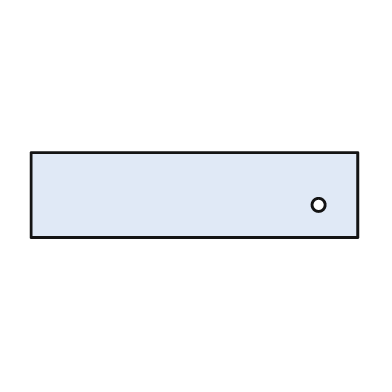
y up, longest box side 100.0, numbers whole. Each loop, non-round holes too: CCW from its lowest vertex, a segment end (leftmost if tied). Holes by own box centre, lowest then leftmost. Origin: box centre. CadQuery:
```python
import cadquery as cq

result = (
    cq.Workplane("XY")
    .moveTo(-50.0, -13.0)
    .lineTo(50.0, -13.0)
    .lineTo(50.0, 13.0)
    .lineTo(-50.0, 13.0)
    .close()
    .moveTo(38.0, -3.0)
    .circle(2.0)
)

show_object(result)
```